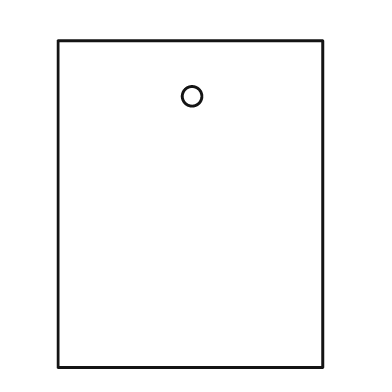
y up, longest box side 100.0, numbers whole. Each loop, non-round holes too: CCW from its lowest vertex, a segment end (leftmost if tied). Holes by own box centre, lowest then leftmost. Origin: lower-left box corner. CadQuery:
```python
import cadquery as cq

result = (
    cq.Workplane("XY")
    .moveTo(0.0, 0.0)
    .lineTo(81.0, 0.0)
    .lineTo(81.0, 100.0)
    .lineTo(0.0, 100.0)
    .close()
    .moveTo(41.0, 83.0)
    .circle(3.0)
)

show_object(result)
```